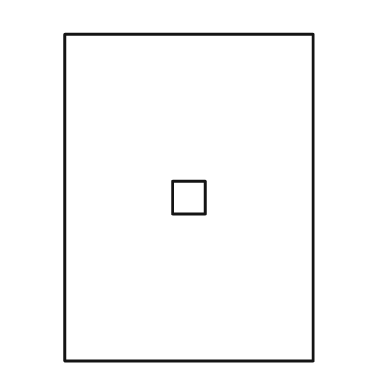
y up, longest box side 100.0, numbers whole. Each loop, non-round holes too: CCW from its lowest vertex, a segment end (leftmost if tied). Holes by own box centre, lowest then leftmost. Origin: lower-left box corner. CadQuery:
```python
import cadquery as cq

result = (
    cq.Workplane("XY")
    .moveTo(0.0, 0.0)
    .lineTo(76.0, 0.0)
    .lineTo(76.0, 100.0)
    .lineTo(0.0, 100.0)
    .close()
    .moveTo(33.0, 45.0)
    .lineTo(43.0, 45.0)
    .lineTo(43.0, 55.0)
    .lineTo(33.0, 55.0)
    .close()
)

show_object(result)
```